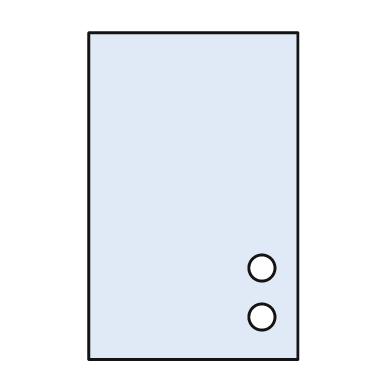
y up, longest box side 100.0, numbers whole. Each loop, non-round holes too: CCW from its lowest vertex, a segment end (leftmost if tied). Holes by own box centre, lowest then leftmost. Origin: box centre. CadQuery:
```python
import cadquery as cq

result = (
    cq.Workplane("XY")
    .moveTo(-32.0, -50.0)
    .lineTo(32.0, -50.0)
    .lineTo(32.0, 50.0)
    .lineTo(-32.0, 50.0)
    .close()
    .moveTo(21.0, -37.0)
    .circle(4.0)
    .moveTo(21.0, -22.0)
    .circle(4.0)
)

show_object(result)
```